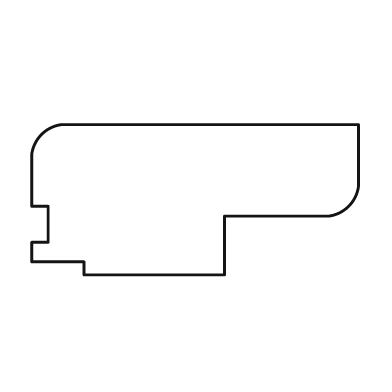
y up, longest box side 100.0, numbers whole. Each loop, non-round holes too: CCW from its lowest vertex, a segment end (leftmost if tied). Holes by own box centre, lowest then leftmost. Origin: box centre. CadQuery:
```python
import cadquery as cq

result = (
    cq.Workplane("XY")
    .moveTo(-34.0, -23.0)
    .lineTo(9.0, -23.0)
    .lineTo(9.0, -5.0)
    .lineTo(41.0, -5.0)
    .threePointArc((47.0, -2.0), (50.0, 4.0))
    .lineTo(50.0, 23.0)
    .lineTo(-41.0, 23.0)
    .threePointArc((-47.0, 20.0), (-50.0, 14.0))
    .lineTo(-50.0, -2.0)
    .lineTo(-45.0, -2.0)
    .lineTo(-45.0, -13.0)
    .lineTo(-50.0, -13.0)
    .lineTo(-50.0, -19.0)
    .lineTo(-34.0, -19.0)
    .close()
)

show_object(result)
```